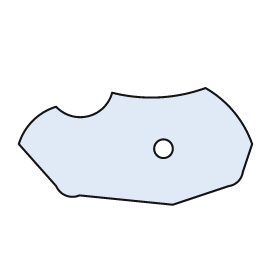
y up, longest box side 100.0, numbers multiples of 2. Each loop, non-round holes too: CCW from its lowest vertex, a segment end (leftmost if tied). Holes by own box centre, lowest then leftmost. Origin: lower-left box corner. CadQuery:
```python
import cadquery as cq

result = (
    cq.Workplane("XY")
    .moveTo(66.0, 0.0)
    .lineTo(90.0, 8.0)
    .threePointArc((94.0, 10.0), (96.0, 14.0))
    .lineTo(100.0, 26.0)
    .threePointArc((92.0, 40.0), (80.0, 50.0))
    .threePointArc((60.0, 46.0), (40.0, 48.0))
    .threePointArc((30.0, 38.0), (16.0, 42.0))
    .threePointArc((6.0, 36.0), (0.0, 26.0))
    .lineTo(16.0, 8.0)
    .threePointArc((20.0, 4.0), (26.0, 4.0))
    .close()
    .moveTo(62.0, 24.0)
    .circle(4.0)
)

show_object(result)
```